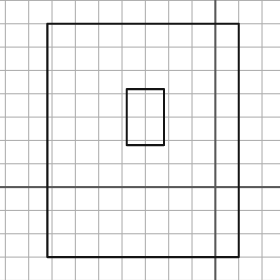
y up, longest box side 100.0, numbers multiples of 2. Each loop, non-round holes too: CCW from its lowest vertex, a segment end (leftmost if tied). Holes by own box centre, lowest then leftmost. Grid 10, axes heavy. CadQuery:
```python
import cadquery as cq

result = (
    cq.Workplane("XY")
    .moveTo(-72.0, -30.0)
    .lineTo(10.0, -30.0)
    .lineTo(10.0, 70.0)
    .lineTo(-72.0, 70.0)
    .close()
    .moveTo(-38.0, 18.0)
    .lineTo(-22.0, 18.0)
    .lineTo(-22.0, 42.0)
    .lineTo(-38.0, 42.0)
    .close()
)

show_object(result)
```